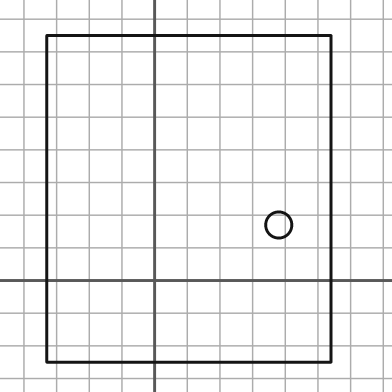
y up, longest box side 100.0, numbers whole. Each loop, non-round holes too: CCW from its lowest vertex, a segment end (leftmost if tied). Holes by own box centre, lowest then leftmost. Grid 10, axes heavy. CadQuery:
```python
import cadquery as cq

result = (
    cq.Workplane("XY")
    .moveTo(-33.0, -25.0)
    .lineTo(54.0, -25.0)
    .lineTo(54.0, 75.0)
    .lineTo(-33.0, 75.0)
    .close()
    .moveTo(38.0, 17.0)
    .circle(4.0)
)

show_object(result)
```